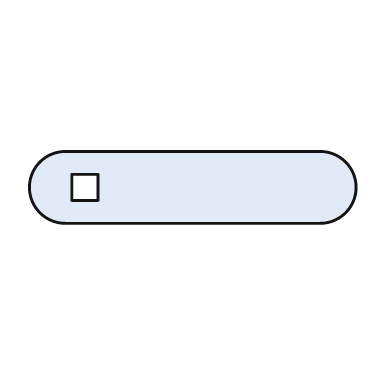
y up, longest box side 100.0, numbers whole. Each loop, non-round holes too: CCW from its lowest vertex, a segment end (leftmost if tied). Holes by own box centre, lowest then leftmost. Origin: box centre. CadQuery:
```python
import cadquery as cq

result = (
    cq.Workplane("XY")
    .moveTo(-39.0, -11.0)
    .lineTo(39.0, -11.0)
    .threePointArc((50.0, 0.0), (39.0, 11.0))
    .lineTo(-39.0, 11.0)
    .threePointArc((-50.0, 0.0), (-39.0, -11.0))
    .close()
    .moveTo(-37.0, -4.0)
    .lineTo(-29.0, -4.0)
    .lineTo(-29.0, 4.0)
    .lineTo(-37.0, 4.0)
    .close()
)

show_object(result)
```